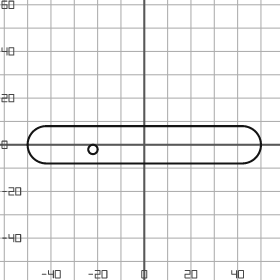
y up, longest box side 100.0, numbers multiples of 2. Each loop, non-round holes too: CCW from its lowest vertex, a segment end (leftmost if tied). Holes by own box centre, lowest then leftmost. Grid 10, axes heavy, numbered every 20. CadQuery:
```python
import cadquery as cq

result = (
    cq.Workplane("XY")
    .moveTo(-42.0, -8.0)
    .lineTo(42.0, -8.0)
    .threePointArc((50.0, 0.0), (42.0, 8.0))
    .lineTo(-42.0, 8.0)
    .threePointArc((-50.0, 0.0), (-42.0, -8.0))
    .close()
    .moveTo(-22.0, -2.0)
    .circle(2.0)
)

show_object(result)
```